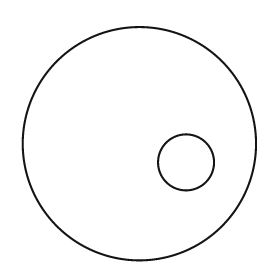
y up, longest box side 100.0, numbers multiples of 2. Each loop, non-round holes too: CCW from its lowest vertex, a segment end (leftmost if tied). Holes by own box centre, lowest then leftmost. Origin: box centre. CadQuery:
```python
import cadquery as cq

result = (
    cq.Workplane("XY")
    .moveTo(0.0, 0.0)
    .circle(50.0)
    .moveTo(20.0, -8.0)
    .circle(12.0)
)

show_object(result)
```